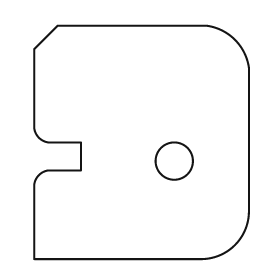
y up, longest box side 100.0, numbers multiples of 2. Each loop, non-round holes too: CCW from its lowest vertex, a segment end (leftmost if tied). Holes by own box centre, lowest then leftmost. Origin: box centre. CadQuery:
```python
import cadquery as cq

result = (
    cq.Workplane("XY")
    .moveTo(-46.0, -50.0)
    .lineTo(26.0, -50.0)
    .threePointArc((40.0, -44.0), (46.0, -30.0))
    .lineTo(46.0, 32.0)
    .threePointArc((40.0, 44.0), (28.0, 50.0))
    .lineTo(-36.0, 50.0)
    .lineTo(-46.0, 40.0)
    .lineTo(-46.0, 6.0)
    .threePointArc((-44.0, 2.0), (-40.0, 0.0))
    .lineTo(-26.0, 0.0)
    .lineTo(-26.0, -12.0)
    .lineTo(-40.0, -12.0)
    .threePointArc((-44.0, -14.0), (-46.0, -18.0))
    .close()
    .moveTo(14.0, -8.0)
    .circle(8.0)
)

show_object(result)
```